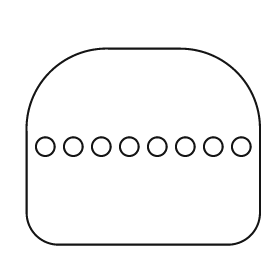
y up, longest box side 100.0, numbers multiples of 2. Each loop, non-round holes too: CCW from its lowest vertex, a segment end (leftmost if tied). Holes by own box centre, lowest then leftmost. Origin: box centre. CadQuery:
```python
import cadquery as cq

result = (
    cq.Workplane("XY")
    .moveTo(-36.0, -42.0)
    .lineTo(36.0, -42.0)
    .threePointArc((46.0, -38.0), (50.0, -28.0))
    .lineTo(50.0, 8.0)
    .threePointArc((40.0, 32.0), (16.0, 42.0))
    .lineTo(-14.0, 42.0)
    .threePointArc((-40.0, 32.0), (-50.0, 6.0))
    .lineTo(-50.0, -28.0)
    .threePointArc((-46.0, -38.0), (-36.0, -42.0))
    .close()
    .moveTo(-42.0, 0.0)
    .circle(4.0)
    .moveTo(-30.0, 0.0)
    .circle(4.0)
    .moveTo(-18.0, 0.0)
    .circle(4.0)
    .moveTo(-6.0, 0.0)
    .circle(4.0)
    .moveTo(6.0, 0.0)
    .circle(4.0)
    .moveTo(18.0, 0.0)
    .circle(4.0)
    .moveTo(30.0, 0.0)
    .circle(4.0)
    .moveTo(42.0, 0.0)
    .circle(4.0)
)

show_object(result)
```